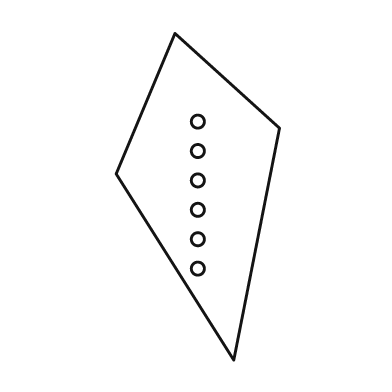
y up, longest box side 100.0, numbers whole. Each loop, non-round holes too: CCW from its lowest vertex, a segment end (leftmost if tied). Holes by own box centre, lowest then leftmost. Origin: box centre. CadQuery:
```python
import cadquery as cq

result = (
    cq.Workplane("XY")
    .moveTo(11.0, -50.0)
    .lineTo(25.0, 21.0)
    .lineTo(-7.0, 50.0)
    .lineTo(-25.0, 7.0)
    .close()
    .moveTo(0.0, -22.0)
    .circle(2.0)
    .moveTo(0.0, -13.0)
    .circle(2.0)
    .moveTo(0.0, -4.0)
    .circle(2.0)
    .moveTo(0.0, 5.0)
    .circle(2.0)
    .moveTo(0.0, 14.0)
    .circle(2.0)
    .moveTo(0.0, 23.0)
    .circle(2.0)
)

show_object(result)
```